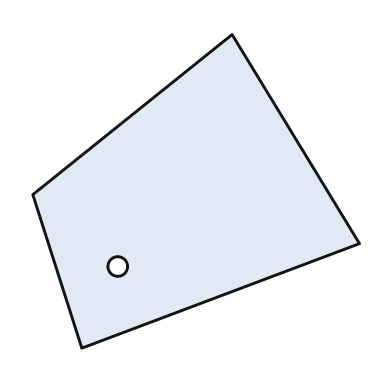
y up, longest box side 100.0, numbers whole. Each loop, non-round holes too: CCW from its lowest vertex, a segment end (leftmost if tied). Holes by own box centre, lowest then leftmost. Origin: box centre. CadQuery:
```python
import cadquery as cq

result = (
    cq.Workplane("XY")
    .moveTo(-35.0, -48.0)
    .lineTo(50.0, -16.0)
    .lineTo(11.0, 48.0)
    .lineTo(-50.0, -1.0)
    .close()
    .moveTo(-24.0, -23.0)
    .circle(3.0)
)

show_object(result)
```